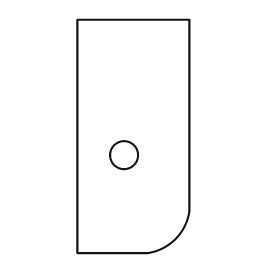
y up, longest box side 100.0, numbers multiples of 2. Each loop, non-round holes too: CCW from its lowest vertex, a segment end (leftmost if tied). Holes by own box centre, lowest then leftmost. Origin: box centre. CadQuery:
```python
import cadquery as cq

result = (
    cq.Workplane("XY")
    .moveTo(-24.0, -50.0)
    .lineTo(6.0, -50.0)
    .threePointArc((18.0, -44.0), (24.0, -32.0))
    .lineTo(24.0, 50.0)
    .lineTo(-24.0, 50.0)
    .close()
    .moveTo(-4.0, -8.0)
    .circle(6.0)
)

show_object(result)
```